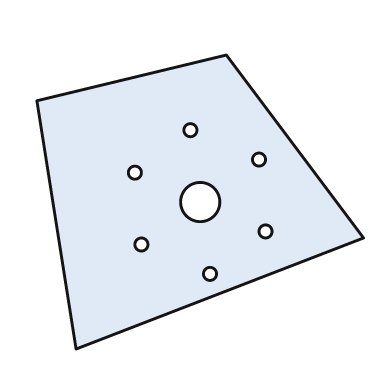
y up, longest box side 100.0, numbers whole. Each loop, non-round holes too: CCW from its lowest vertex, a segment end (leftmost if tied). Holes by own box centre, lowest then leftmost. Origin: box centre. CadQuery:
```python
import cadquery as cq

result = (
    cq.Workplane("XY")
    .moveTo(-38.0, -45.0)
    .lineTo(50.0, -11.0)
    .lineTo(8.0, 45.0)
    .lineTo(-50.0, 31.0)
    .close()
    .moveTo(3.0, -22.0)
    .circle(2.0)
    .moveTo(-18.0, -13.0)
    .circle(2.0)
    .moveTo(20.0, -9.0)
    .circle(2.0)
    .moveTo(0.0, 0.0)
    .circle(6.0)
    .moveTo(-20.0, 9.0)
    .circle(2.0)
    .moveTo(18.0, 13.0)
    .circle(2.0)
    .moveTo(-3.0, 22.0)
    .circle(2.0)
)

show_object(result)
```